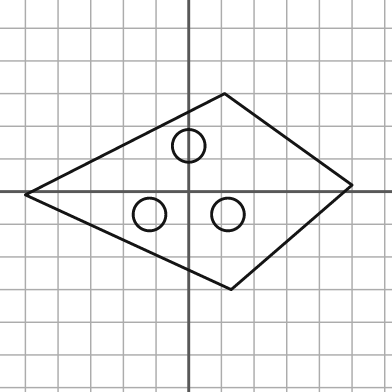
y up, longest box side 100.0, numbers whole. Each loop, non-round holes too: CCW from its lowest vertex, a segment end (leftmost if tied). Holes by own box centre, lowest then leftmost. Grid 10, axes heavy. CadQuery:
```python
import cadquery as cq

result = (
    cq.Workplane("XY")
    .moveTo(13.0, -30.0)
    .lineTo(50.0, 2.0)
    .lineTo(11.0, 30.0)
    .lineTo(-50.0, -1.0)
    .close()
    .moveTo(-12.0, -7.0)
    .circle(5.0)
    .moveTo(12.0, -7.0)
    .circle(5.0)
    .moveTo(0.0, 14.0)
    .circle(5.0)
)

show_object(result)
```